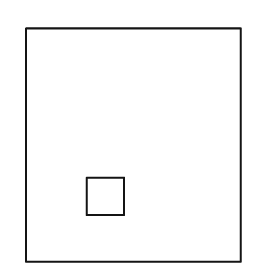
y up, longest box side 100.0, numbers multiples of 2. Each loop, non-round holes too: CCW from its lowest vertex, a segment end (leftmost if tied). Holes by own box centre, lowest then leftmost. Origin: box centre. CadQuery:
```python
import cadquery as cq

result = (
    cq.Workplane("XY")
    .moveTo(-46.0, -50.0)
    .lineTo(46.0, -50.0)
    .lineTo(46.0, 50.0)
    .lineTo(-46.0, 50.0)
    .close()
    .moveTo(-20.0, -30.0)
    .lineTo(-4.0, -30.0)
    .lineTo(-4.0, -14.0)
    .lineTo(-20.0, -14.0)
    .close()
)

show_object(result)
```